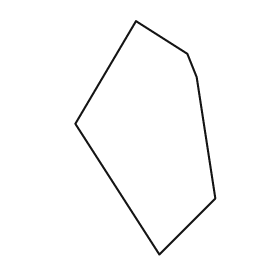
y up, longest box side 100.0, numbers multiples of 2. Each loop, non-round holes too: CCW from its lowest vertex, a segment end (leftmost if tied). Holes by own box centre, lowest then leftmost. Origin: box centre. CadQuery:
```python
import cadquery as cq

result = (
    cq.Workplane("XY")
    .moveTo(6.0, -50.0)
    .lineTo(30.0, -26.0)
    .lineTo(22.0, 26.0)
    .lineTo(18.0, 36.0)
    .lineTo(-4.0, 50.0)
    .lineTo(-30.0, 6.0)
    .close()
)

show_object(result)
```